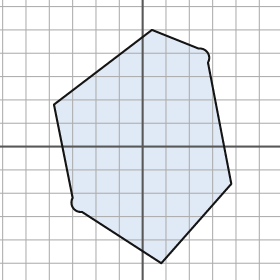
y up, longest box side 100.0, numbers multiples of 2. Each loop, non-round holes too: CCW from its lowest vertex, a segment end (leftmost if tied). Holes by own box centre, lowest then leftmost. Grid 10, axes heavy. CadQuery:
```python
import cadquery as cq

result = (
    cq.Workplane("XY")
    .moveTo(8.0, -50.0)
    .lineTo(38.0, -16.0)
    .lineTo(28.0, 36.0)
    .threePointArc((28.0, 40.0), (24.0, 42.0))
    .lineTo(4.0, 50.0)
    .lineTo(-38.0, 18.0)
    .lineTo(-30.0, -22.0)
    .threePointArc((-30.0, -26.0), (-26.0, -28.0))
    .close()
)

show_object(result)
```